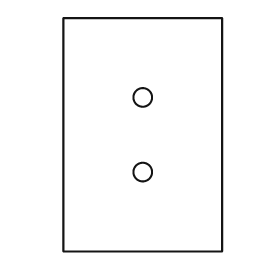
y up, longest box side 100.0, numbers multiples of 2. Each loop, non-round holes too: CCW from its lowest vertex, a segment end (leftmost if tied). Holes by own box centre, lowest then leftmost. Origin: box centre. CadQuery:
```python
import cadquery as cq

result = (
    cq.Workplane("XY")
    .moveTo(-34.0, -50.0)
    .lineTo(34.0, -50.0)
    .lineTo(34.0, 50.0)
    .lineTo(-34.0, 50.0)
    .close()
    .moveTo(0.0, -16.0)
    .circle(4.0)
    .moveTo(0.0, 16.0)
    .circle(4.0)
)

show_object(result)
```